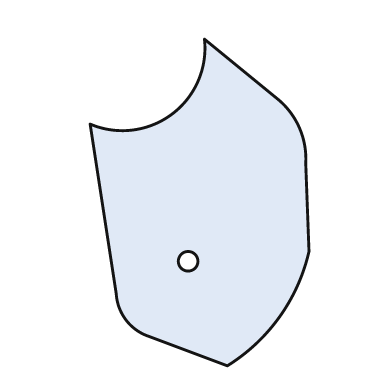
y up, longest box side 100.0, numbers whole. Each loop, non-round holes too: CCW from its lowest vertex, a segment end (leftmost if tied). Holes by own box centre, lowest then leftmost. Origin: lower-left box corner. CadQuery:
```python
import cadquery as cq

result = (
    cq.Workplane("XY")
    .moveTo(42.0, 0.0)
    .threePointArc((58.0, 15.0), (67.0, 35.0))
    .lineTo(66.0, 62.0)
    .threePointArc((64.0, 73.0), (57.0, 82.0))
    .lineTo(35.0, 100.0)
    .threePointArc((25.0, 77.0), (0.0, 74.0))
    .lineTo(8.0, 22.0)
    .threePointArc((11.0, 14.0), (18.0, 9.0))
    .close()
    .moveTo(30.0, 32.0)
    .circle(3.0)
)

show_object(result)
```